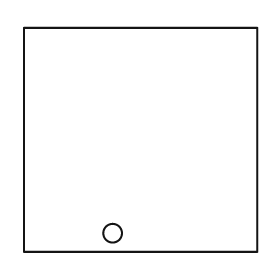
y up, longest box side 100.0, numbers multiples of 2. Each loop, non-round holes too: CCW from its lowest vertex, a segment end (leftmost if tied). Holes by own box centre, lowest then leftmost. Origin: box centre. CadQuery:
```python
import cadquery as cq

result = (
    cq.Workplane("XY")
    .moveTo(-50.0, -48.0)
    .lineTo(50.0, -48.0)
    .lineTo(50.0, 48.0)
    .lineTo(-50.0, 48.0)
    .close()
    .moveTo(-12.0, -40.0)
    .circle(4.0)
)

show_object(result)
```